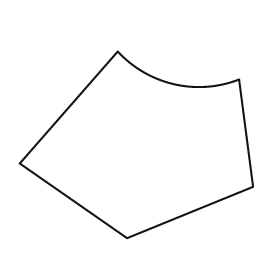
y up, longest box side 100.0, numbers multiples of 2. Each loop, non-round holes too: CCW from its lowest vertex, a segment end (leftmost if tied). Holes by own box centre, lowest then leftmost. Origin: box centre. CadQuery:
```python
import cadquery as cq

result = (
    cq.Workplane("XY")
    .moveTo(-4.0, -40.0)
    .lineTo(50.0, -18.0)
    .lineTo(44.0, 28.0)
    .threePointArc((16.0, 26.0), (-8.0, 40.0))
    .lineTo(-50.0, -8.0)
    .close()
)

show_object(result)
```